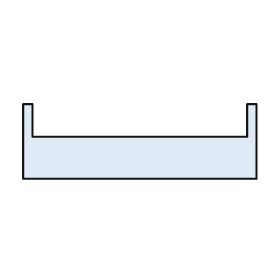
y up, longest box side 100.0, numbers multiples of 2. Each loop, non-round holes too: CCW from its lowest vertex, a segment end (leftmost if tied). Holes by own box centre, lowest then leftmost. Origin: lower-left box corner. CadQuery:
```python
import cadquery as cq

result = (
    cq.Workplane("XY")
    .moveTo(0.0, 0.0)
    .lineTo(100.0, 0.0)
    .lineTo(100.0, 32.0)
    .lineTo(96.0, 32.0)
    .lineTo(96.0, 18.0)
    .lineTo(4.0, 18.0)
    .lineTo(4.0, 32.0)
    .lineTo(0.0, 32.0)
    .close()
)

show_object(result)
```